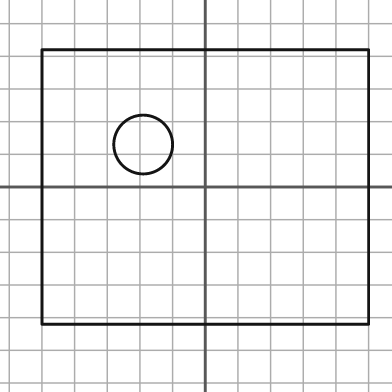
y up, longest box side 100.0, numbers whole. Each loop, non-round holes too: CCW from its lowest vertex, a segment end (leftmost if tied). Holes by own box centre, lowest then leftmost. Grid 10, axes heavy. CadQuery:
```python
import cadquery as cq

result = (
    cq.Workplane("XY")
    .moveTo(-50.0, -42.0)
    .lineTo(50.0, -42.0)
    .lineTo(50.0, 42.0)
    .lineTo(-50.0, 42.0)
    .close()
    .moveTo(-19.0, 13.0)
    .circle(9.0)
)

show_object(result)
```